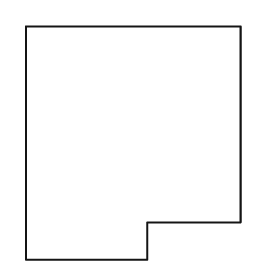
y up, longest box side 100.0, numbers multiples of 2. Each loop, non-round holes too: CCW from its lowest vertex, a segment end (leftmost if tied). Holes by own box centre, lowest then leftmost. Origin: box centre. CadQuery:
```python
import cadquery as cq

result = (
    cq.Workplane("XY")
    .moveTo(-46.0, -50.0)
    .lineTo(6.0, -50.0)
    .lineTo(6.0, -34.0)
    .lineTo(46.0, -34.0)
    .lineTo(46.0, 50.0)
    .lineTo(-46.0, 50.0)
    .close()
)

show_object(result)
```